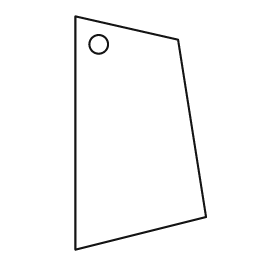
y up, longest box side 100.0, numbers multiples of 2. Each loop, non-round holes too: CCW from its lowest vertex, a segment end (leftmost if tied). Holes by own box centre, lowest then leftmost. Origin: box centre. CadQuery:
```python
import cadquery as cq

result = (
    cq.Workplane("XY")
    .moveTo(-28.0, -50.0)
    .lineTo(28.0, -36.0)
    .lineTo(16.0, 40.0)
    .lineTo(-28.0, 50.0)
    .close()
    .moveTo(-18.0, 38.0)
    .circle(4.0)
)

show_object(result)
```